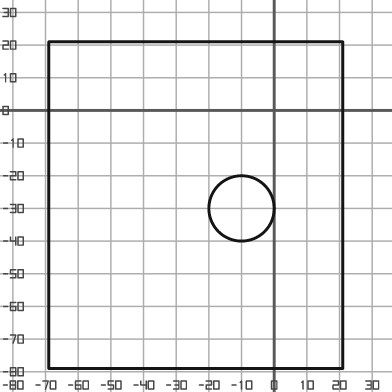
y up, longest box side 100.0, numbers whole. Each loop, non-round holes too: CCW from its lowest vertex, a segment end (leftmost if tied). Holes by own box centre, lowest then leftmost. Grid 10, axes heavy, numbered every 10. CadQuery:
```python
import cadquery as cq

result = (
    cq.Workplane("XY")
    .moveTo(-69.0, -79.0)
    .lineTo(21.0, -79.0)
    .lineTo(21.0, 21.0)
    .lineTo(-69.0, 21.0)
    .close()
    .moveTo(-10.0, -30.0)
    .circle(10.0)
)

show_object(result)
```